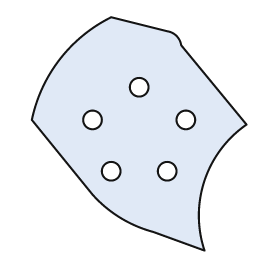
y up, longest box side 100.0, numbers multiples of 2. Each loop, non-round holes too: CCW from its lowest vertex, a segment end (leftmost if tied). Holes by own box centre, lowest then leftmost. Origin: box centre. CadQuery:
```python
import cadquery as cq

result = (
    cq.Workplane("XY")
    .moveTo(28.0, -50.0)
    .threePointArc((28.0, -20.0), (46.0, 4.0))
    .lineTo(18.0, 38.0)
    .threePointArc((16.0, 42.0), (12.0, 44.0))
    .lineTo(-12.0, 50.0)
    .threePointArc((-34.0, 32.0), (-46.0, 6.0))
    .lineTo(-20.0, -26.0)
    .threePointArc((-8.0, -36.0), (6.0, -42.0))
    .close()
    .moveTo(-12.0, -16.0)
    .circle(4.0)
    .moveTo(12.0, -16.0)
    .circle(4.0)
    .moveTo(-20.0, 6.0)
    .circle(4.0)
    .moveTo(20.0, 6.0)
    .circle(4.0)
    .moveTo(0.0, 20.0)
    .circle(4.0)
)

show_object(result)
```